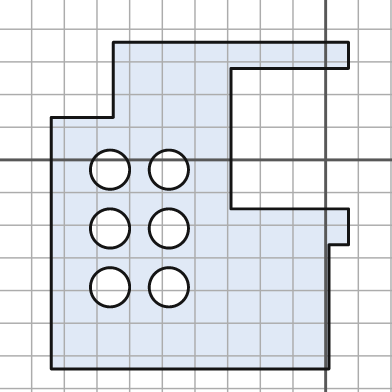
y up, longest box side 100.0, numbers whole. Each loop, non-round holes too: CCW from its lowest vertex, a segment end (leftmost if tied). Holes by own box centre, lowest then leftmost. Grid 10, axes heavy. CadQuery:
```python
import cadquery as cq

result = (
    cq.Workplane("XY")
    .moveTo(-84.0, -64.0)
    .lineTo(1.0, -64.0)
    .lineTo(1.0, -26.0)
    .lineTo(7.0, -26.0)
    .lineTo(7.0, -15.0)
    .lineTo(-29.0, -15.0)
    .lineTo(-29.0, 28.0)
    .lineTo(7.0, 28.0)
    .lineTo(7.0, 36.0)
    .lineTo(-65.0, 36.0)
    .lineTo(-65.0, 13.0)
    .lineTo(-84.0, 13.0)
    .close()
    .moveTo(-66.0, -39.0)
    .circle(6.0)
    .moveTo(-48.0, -39.0)
    .circle(6.0)
    .moveTo(-66.0, -21.0)
    .circle(6.0)
    .moveTo(-48.0, -21.0)
    .circle(6.0)
    .moveTo(-66.0, -3.0)
    .circle(6.0)
    .moveTo(-48.0, -3.0)
    .circle(6.0)
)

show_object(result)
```